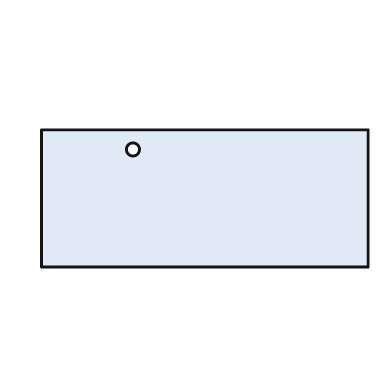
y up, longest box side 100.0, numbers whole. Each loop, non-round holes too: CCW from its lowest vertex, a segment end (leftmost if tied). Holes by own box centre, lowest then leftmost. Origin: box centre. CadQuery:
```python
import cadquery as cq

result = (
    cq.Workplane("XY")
    .moveTo(-50.0, -21.0)
    .lineTo(50.0, -21.0)
    .lineTo(50.0, 21.0)
    .lineTo(-50.0, 21.0)
    .close()
    .moveTo(-22.0, 15.0)
    .circle(2.0)
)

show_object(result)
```